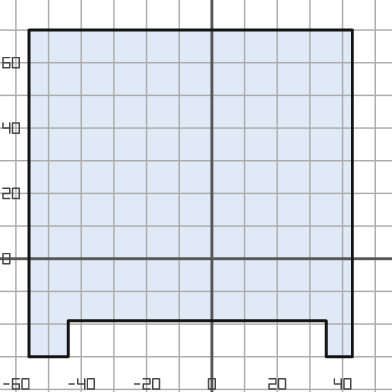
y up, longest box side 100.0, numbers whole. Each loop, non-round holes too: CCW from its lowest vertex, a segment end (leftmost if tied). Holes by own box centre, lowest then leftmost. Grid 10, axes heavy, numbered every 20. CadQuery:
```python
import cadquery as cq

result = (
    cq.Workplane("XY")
    .moveTo(-56.0, -30.0)
    .lineTo(-44.0, -30.0)
    .lineTo(-44.0, -19.0)
    .lineTo(35.0, -19.0)
    .lineTo(35.0, -30.0)
    .lineTo(43.0, -30.0)
    .lineTo(43.0, 70.0)
    .lineTo(-56.0, 70.0)
    .close()
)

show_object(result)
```